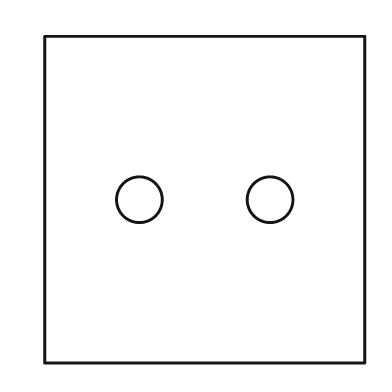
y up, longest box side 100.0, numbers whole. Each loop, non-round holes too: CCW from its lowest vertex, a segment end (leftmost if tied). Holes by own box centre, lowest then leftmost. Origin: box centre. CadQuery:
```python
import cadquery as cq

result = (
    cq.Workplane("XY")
    .moveTo(-49.0, -50.0)
    .lineTo(49.0, -50.0)
    .lineTo(49.0, 50.0)
    .lineTo(-49.0, 50.0)
    .close()
    .moveTo(-20.0, 0.0)
    .circle(7.0)
    .moveTo(20.0, 0.0)
    .circle(7.0)
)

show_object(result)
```